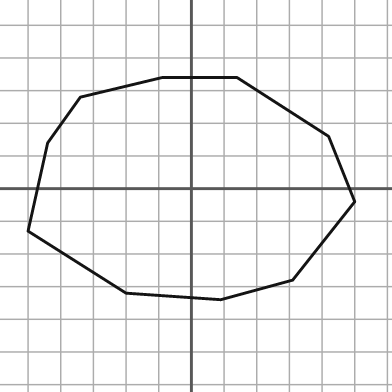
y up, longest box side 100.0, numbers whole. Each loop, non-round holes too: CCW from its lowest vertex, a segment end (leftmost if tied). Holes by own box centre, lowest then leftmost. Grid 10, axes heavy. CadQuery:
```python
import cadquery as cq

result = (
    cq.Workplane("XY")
    .moveTo(9.0, -34.0)
    .lineTo(31.0, -28.0)
    .lineTo(50.0, -4.0)
    .lineTo(42.0, 16.0)
    .lineTo(14.0, 34.0)
    .lineTo(-9.0, 34.0)
    .lineTo(-34.0, 28.0)
    .lineTo(-44.0, 14.0)
    .lineTo(-50.0, -13.0)
    .lineTo(-20.0, -32.0)
    .close()
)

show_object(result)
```